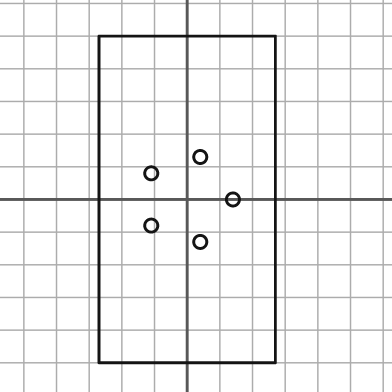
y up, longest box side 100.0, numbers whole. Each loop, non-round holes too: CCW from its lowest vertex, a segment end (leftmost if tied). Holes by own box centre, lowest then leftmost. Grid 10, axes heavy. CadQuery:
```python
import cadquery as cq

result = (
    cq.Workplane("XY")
    .moveTo(-27.0, -50.0)
    .lineTo(27.0, -50.0)
    .lineTo(27.0, 50.0)
    .lineTo(-27.0, 50.0)
    .close()
    .moveTo(4.0, -13.0)
    .circle(2.0)
    .moveTo(-11.0, -8.0)
    .circle(2.0)
    .moveTo(14.0, 0.0)
    .circle(2.0)
    .moveTo(-11.0, 8.0)
    .circle(2.0)
    .moveTo(4.0, 13.0)
    .circle(2.0)
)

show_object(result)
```